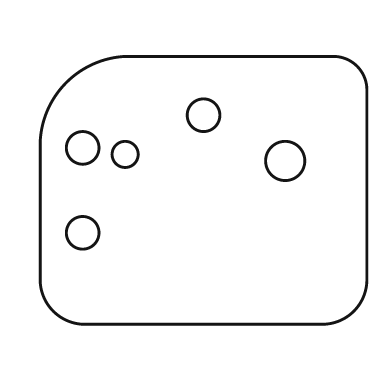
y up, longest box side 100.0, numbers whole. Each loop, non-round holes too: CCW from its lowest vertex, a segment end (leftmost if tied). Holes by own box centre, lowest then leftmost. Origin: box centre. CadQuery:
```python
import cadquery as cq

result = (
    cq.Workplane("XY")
    .moveTo(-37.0, -41.0)
    .lineTo(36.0, -41.0)
    .threePointArc((46.0, -37.0), (50.0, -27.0))
    .lineTo(50.0, 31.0)
    .threePointArc((47.0, 38.0), (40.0, 41.0))
    .lineTo(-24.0, 41.0)
    .threePointArc((-42.0, 33.0), (-50.0, 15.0))
    .lineTo(-50.0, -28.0)
    .threePointArc((-46.0, -37.0), (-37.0, -41.0))
    .close()
    .moveTo(-37.0, -13.0)
    .circle(5.0)
    .moveTo(25.0, 9.0)
    .circle(6.0)
    .moveTo(-24.0, 11.0)
    .circle(4.0)
    .moveTo(-37.0, 13.0)
    .circle(5.0)
    .moveTo(0.0, 23.0)
    .circle(5.0)
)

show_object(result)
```